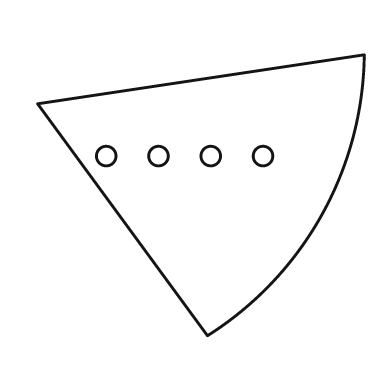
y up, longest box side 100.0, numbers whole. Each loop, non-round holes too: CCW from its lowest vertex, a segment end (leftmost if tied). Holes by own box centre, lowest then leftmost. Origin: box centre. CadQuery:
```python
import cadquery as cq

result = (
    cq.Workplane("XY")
    .moveTo(2.0, -43.0)
    .threePointArc((37.0, -6.0), (50.0, 43.0))
    .lineTo(-50.0, 28.0)
    .close()
    .moveTo(-29.0, 12.0)
    .circle(3.0)
    .moveTo(-13.0, 12.0)
    .circle(3.0)
    .moveTo(3.0, 12.0)
    .circle(3.0)
    .moveTo(19.0, 12.0)
    .circle(3.0)
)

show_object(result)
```